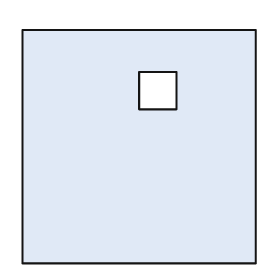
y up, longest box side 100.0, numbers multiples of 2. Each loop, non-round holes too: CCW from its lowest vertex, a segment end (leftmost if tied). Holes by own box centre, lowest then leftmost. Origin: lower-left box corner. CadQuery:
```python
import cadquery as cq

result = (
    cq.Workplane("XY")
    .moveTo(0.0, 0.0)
    .lineTo(100.0, 0.0)
    .lineTo(100.0, 100.0)
    .lineTo(0.0, 100.0)
    .close()
    .moveTo(50.0, 66.0)
    .lineTo(66.0, 66.0)
    .lineTo(66.0, 82.0)
    .lineTo(50.0, 82.0)
    .close()
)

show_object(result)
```